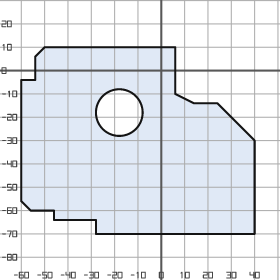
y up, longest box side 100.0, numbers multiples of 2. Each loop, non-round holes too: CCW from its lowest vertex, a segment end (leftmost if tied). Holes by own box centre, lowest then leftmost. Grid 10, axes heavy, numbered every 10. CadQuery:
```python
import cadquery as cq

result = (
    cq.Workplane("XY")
    .moveTo(-28.0, -70.0)
    .lineTo(40.0, -70.0)
    .lineTo(40.0, -30.0)
    .lineTo(24.0, -14.0)
    .lineTo(14.0, -14.0)
    .lineTo(6.0, -10.0)
    .lineTo(6.0, 10.0)
    .lineTo(-50.0, 10.0)
    .lineTo(-54.0, 6.0)
    .lineTo(-54.0, -4.0)
    .lineTo(-60.0, -4.0)
    .lineTo(-60.0, -56.0)
    .lineTo(-56.0, -60.0)
    .lineTo(-46.0, -60.0)
    .lineTo(-46.0, -64.0)
    .lineTo(-28.0, -64.0)
    .close()
    .moveTo(-18.0, -18.0)
    .circle(10.0)
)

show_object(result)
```